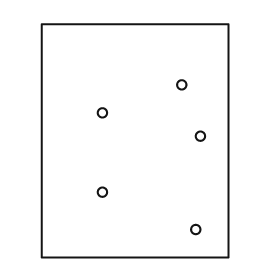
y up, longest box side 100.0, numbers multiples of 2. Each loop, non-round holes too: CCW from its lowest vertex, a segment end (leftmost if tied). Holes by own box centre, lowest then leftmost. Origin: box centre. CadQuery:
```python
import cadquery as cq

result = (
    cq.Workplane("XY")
    .moveTo(-40.0, -50.0)
    .lineTo(40.0, -50.0)
    .lineTo(40.0, 50.0)
    .lineTo(-40.0, 50.0)
    .close()
    .moveTo(26.0, -38.0)
    .circle(2.0)
    .moveTo(-14.0, -22.0)
    .circle(2.0)
    .moveTo(28.0, 2.0)
    .circle(2.0)
    .moveTo(-14.0, 12.0)
    .circle(2.0)
    .moveTo(20.0, 24.0)
    .circle(2.0)
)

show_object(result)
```